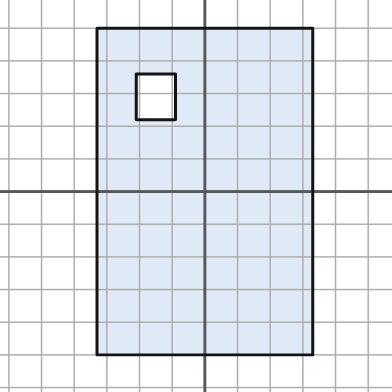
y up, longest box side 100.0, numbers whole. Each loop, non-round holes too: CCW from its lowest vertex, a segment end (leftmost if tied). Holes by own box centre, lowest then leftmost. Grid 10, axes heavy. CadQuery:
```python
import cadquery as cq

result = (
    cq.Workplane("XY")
    .moveTo(-33.0, -50.0)
    .lineTo(33.0, -50.0)
    .lineTo(33.0, 50.0)
    .lineTo(-33.0, 50.0)
    .close()
    .moveTo(-21.0, 22.0)
    .lineTo(-9.0, 22.0)
    .lineTo(-9.0, 36.0)
    .lineTo(-21.0, 36.0)
    .close()
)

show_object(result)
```